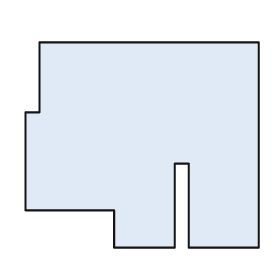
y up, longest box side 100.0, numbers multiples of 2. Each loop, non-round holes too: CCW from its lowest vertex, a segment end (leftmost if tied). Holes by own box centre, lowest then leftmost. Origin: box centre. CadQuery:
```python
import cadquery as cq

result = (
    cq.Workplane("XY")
    .moveTo(-12.0, -44.0)
    .lineTo(14.0, -44.0)
    .lineTo(14.0, -8.0)
    .lineTo(20.0, -8.0)
    .lineTo(20.0, -44.0)
    .lineTo(50.0, -44.0)
    .lineTo(50.0, 44.0)
    .lineTo(-44.0, 44.0)
    .lineTo(-44.0, 14.0)
    .lineTo(-50.0, 14.0)
    .lineTo(-50.0, -28.0)
    .lineTo(-12.0, -28.0)
    .close()
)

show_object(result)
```